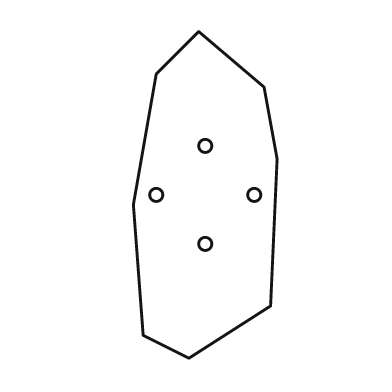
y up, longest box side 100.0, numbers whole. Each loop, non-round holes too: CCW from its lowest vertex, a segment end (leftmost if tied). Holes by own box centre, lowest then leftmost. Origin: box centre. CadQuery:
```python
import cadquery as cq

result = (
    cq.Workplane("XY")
    .moveTo(-5.0, -50.0)
    .lineTo(20.0, -34.0)
    .lineTo(22.0, 11.0)
    .lineTo(18.0, 33.0)
    .lineTo(-2.0, 50.0)
    .lineTo(-15.0, 37.0)
    .lineTo(-22.0, -3.0)
    .lineTo(-19.0, -43.0)
    .close()
    .moveTo(0.0, -15.0)
    .circle(2.0)
    .moveTo(-15.0, 0.0)
    .circle(2.0)
    .moveTo(15.0, 0.0)
    .circle(2.0)
    .moveTo(0.0, 15.0)
    .circle(2.0)
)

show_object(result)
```